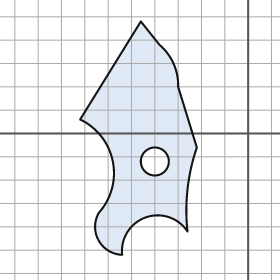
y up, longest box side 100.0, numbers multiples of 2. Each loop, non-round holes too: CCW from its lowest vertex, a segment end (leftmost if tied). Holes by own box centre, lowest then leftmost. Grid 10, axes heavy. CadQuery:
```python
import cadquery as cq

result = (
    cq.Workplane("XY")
    .moveTo(-54.0, -52.0)
    .threePointArc((-44.0, -36.0), (-26.0, -42.0))
    .threePointArc((-26.0, -24.0), (-22.0, -6.0))
    .lineTo(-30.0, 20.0)
    .threePointArc((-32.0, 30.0), (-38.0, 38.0))
    .lineTo(-46.0, 48.0)
    .lineTo(-72.0, 6.0)
    .threePointArc((-58.0, -12.0), (-64.0, -34.0))
    .threePointArc((-64.0, -46.0), (-54.0, -52.0))
    .close()
    .moveTo(-40.0, -12.0)
    .circle(6.0)
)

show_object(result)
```